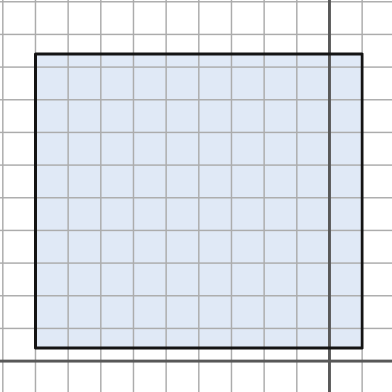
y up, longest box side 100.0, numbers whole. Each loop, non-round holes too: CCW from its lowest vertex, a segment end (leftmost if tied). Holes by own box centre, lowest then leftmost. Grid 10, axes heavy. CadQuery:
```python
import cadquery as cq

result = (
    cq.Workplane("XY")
    .moveTo(-90.0, 4.0)
    .lineTo(10.0, 4.0)
    .lineTo(10.0, 94.0)
    .lineTo(-90.0, 94.0)
    .close()
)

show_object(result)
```